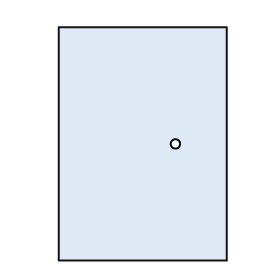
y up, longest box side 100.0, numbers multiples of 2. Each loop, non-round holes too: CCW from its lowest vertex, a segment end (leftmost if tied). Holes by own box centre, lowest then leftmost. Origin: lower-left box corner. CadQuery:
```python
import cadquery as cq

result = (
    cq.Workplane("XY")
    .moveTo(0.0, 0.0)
    .lineTo(72.0, 0.0)
    .lineTo(72.0, 100.0)
    .lineTo(0.0, 100.0)
    .close()
    .moveTo(50.0, 50.0)
    .circle(2.0)
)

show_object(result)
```